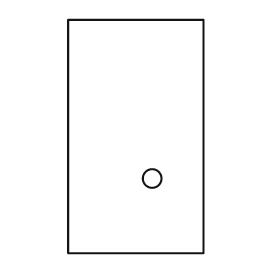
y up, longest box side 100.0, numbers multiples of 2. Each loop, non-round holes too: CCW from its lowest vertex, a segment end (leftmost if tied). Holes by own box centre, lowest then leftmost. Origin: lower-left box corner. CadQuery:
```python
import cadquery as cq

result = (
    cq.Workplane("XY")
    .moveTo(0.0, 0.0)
    .lineTo(58.0, 0.0)
    .lineTo(58.0, 100.0)
    .lineTo(0.0, 100.0)
    .close()
    .moveTo(36.0, 32.0)
    .circle(4.0)
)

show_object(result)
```